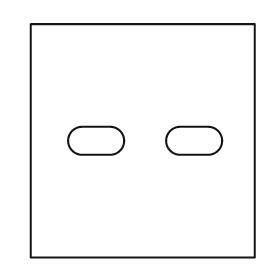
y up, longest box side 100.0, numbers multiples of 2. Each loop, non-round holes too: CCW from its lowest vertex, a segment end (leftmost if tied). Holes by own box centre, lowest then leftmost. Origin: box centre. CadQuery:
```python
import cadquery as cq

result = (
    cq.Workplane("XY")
    .moveTo(-48.0, -50.0)
    .lineTo(48.0, -50.0)
    .lineTo(48.0, 50.0)
    .lineTo(-48.0, 50.0)
    .close()
    .moveTo(-26.0, -6.0)
    .lineTo(-14.0, -6.0)
    .threePointArc((-8.0, 0.0), (-14.0, 6.0))
    .lineTo(-26.0, 6.0)
    .threePointArc((-32.0, 0.0), (-26.0, -6.0))
    .close()
    .moveTo(16.0, -6.0)
    .lineTo(28.0, -6.0)
    .threePointArc((34.0, 0.0), (28.0, 6.0))
    .lineTo(16.0, 6.0)
    .threePointArc((10.0, 0.0), (16.0, -6.0))
    .close()
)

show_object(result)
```